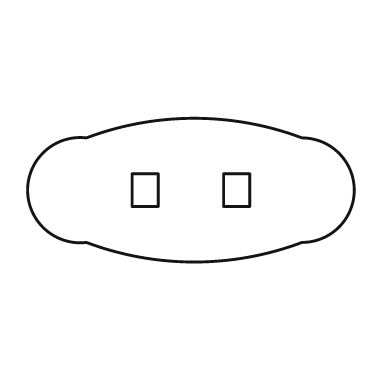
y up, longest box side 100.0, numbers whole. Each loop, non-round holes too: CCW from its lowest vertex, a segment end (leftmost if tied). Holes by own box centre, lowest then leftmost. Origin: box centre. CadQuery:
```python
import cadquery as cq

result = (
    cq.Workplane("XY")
    .moveTo(-32.0, -16.0)
    .threePointArc((1.0, -22.0), (34.0, -16.0))
    .threePointArc((50.0, 0.0), (34.0, 16.0))
    .threePointArc((1.0, 22.0), (-32.0, 16.0))
    .threePointArc((-50.0, 0.0), (-32.0, -16.0))
    .close()
    .moveTo(-18.0, -5.0)
    .lineTo(-10.0, -5.0)
    .lineTo(-10.0, 5.0)
    .lineTo(-18.0, 5.0)
    .close()
    .moveTo(10.0, -5.0)
    .lineTo(18.0, -5.0)
    .lineTo(18.0, 5.0)
    .lineTo(10.0, 5.0)
    .close()
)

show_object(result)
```